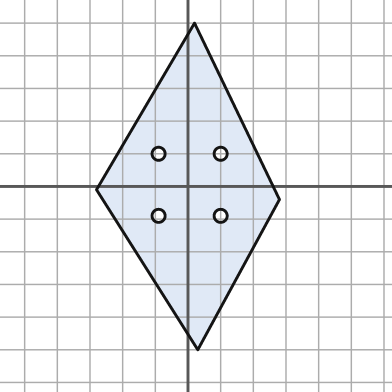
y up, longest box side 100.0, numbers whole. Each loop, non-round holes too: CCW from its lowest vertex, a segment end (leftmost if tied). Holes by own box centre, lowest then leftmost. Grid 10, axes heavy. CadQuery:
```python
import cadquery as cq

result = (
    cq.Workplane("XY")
    .moveTo(3.0, -50.0)
    .lineTo(28.0, -4.0)
    .lineTo(2.0, 50.0)
    .lineTo(-28.0, -1.0)
    .close()
    .moveTo(-9.0, -9.0)
    .circle(2.0)
    .moveTo(10.0, -9.0)
    .circle(2.0)
    .moveTo(-9.0, 10.0)
    .circle(2.0)
    .moveTo(10.0, 10.0)
    .circle(2.0)
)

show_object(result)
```